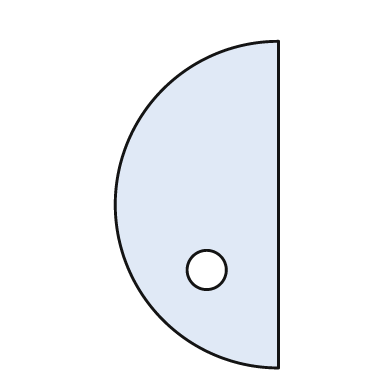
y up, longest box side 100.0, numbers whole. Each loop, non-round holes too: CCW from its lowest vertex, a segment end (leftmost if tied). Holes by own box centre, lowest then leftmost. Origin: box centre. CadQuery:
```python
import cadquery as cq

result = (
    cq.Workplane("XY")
    .moveTo(25.0, -50.0)
    .lineTo(25.0, 50.0)
    .threePointArc((-25.0, 0.0), (25.0, -50.0))
    .close()
    .moveTo(3.0, -20.0)
    .circle(6.0)
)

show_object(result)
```